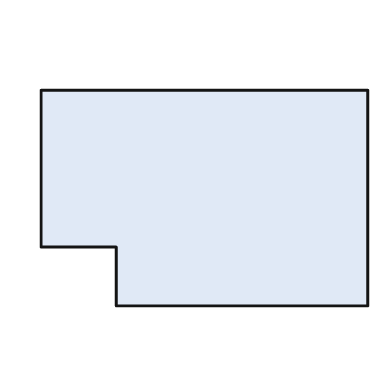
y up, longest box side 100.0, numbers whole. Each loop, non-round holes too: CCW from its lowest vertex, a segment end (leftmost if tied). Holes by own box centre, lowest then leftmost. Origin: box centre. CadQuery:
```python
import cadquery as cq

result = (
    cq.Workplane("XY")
    .moveTo(-27.0, -33.0)
    .lineTo(50.0, -33.0)
    .lineTo(50.0, 33.0)
    .lineTo(-50.0, 33.0)
    .lineTo(-50.0, -15.0)
    .lineTo(-27.0, -15.0)
    .close()
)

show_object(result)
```